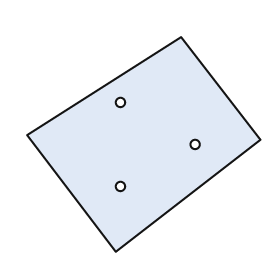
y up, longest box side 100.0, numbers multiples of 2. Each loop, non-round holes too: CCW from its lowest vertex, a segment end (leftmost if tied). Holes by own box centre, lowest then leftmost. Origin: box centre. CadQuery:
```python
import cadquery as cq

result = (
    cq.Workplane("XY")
    .moveTo(-12.0, -46.0)
    .lineTo(50.0, 2.0)
    .lineTo(16.0, 46.0)
    .lineTo(-50.0, 4.0)
    .close()
    .moveTo(-10.0, -18.0)
    .circle(2.0)
    .moveTo(22.0, 0.0)
    .circle(2.0)
    .moveTo(-10.0, 18.0)
    .circle(2.0)
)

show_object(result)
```